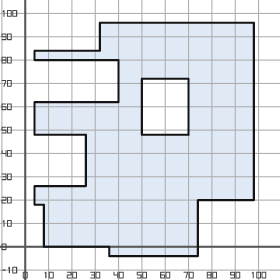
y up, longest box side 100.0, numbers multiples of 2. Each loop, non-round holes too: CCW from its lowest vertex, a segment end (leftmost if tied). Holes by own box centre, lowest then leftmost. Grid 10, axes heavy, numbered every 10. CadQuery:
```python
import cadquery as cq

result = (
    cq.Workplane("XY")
    .moveTo(36.0, -4.0)
    .lineTo(74.0, -4.0)
    .lineTo(74.0, 20.0)
    .lineTo(98.0, 20.0)
    .lineTo(98.0, 96.0)
    .lineTo(32.0, 96.0)
    .lineTo(32.0, 84.0)
    .lineTo(4.0, 84.0)
    .lineTo(4.0, 80.0)
    .lineTo(40.0, 80.0)
    .lineTo(40.0, 62.0)
    .lineTo(4.0, 62.0)
    .lineTo(4.0, 48.0)
    .lineTo(26.0, 48.0)
    .lineTo(26.0, 26.0)
    .lineTo(4.0, 26.0)
    .lineTo(4.0, 18.0)
    .lineTo(8.0, 18.0)
    .lineTo(8.0, 0.0)
    .lineTo(36.0, 0.0)
    .close()
    .moveTo(50.0, 48.0)
    .lineTo(70.0, 48.0)
    .lineTo(70.0, 72.0)
    .lineTo(50.0, 72.0)
    .close()
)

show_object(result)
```